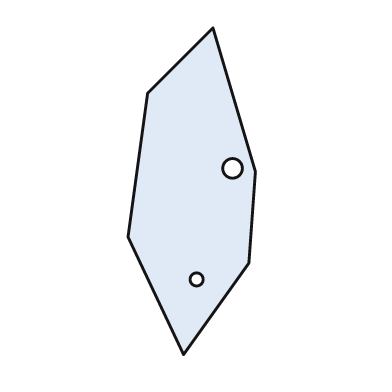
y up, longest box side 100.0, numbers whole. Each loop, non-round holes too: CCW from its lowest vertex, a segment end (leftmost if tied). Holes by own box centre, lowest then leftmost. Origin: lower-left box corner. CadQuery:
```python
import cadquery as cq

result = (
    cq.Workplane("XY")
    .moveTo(17.0, 0.0)
    .lineTo(37.0, 28.0)
    .lineTo(39.0, 56.0)
    .lineTo(26.0, 100.0)
    .lineTo(6.0, 80.0)
    .lineTo(0.0, 36.0)
    .close()
    .moveTo(21.0, 23.0)
    .circle(2.0)
    .moveTo(32.0, 57.0)
    .circle(3.0)
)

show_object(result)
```